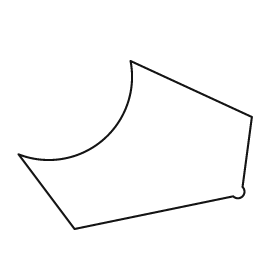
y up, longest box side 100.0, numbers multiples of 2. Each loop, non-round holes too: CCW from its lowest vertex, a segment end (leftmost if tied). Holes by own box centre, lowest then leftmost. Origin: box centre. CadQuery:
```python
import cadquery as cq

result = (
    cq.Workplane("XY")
    .moveTo(-26.0, -36.0)
    .lineTo(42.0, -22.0)
    .threePointArc((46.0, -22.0), (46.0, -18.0))
    .lineTo(50.0, 12.0)
    .lineTo(-2.0, 36.0)
    .threePointArc((-14.0, 2.0), (-50.0, -4.0))
    .close()
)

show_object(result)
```